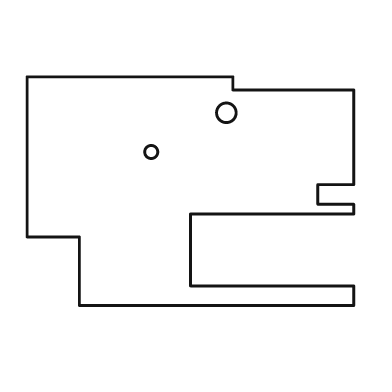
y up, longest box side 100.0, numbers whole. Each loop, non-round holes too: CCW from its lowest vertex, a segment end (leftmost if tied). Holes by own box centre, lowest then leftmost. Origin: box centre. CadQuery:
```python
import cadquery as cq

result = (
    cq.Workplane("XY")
    .moveTo(-34.0, -35.0)
    .lineTo(50.0, -35.0)
    .lineTo(50.0, -29.0)
    .lineTo(0.0, -29.0)
    .lineTo(0.0, -7.0)
    .lineTo(50.0, -7.0)
    .lineTo(50.0, -4.0)
    .lineTo(39.0, -4.0)
    .lineTo(39.0, 2.0)
    .lineTo(50.0, 2.0)
    .lineTo(50.0, 31.0)
    .lineTo(13.0, 31.0)
    .lineTo(13.0, 35.0)
    .lineTo(-50.0, 35.0)
    .lineTo(-50.0, -14.0)
    .lineTo(-34.0, -14.0)
    .close()
    .moveTo(-12.0, 12.0)
    .circle(2.0)
    .moveTo(11.0, 24.0)
    .circle(3.0)
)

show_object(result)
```